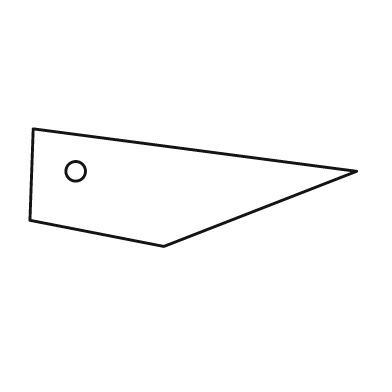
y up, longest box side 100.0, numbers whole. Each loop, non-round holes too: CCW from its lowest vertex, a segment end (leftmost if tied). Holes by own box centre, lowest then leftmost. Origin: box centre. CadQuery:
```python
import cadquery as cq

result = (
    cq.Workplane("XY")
    .moveTo(-9.0, -18.0)
    .lineTo(50.0, 5.0)
    .lineTo(-49.0, 18.0)
    .lineTo(-50.0, -10.0)
    .close()
    .moveTo(-36.0, 5.0)
    .circle(3.0)
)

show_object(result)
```